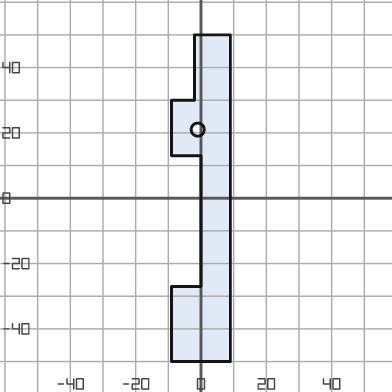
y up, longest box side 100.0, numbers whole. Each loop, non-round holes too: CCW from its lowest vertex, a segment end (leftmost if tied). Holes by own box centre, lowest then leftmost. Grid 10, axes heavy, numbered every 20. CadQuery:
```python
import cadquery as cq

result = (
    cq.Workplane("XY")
    .moveTo(-9.0, -50.0)
    .lineTo(9.0, -50.0)
    .lineTo(9.0, 50.0)
    .lineTo(-2.0, 50.0)
    .lineTo(-2.0, 30.0)
    .lineTo(-9.0, 30.0)
    .lineTo(-9.0, 13.0)
    .lineTo(0.0, 13.0)
    .lineTo(0.0, -27.0)
    .lineTo(-9.0, -27.0)
    .close()
    .moveTo(-1.0, 21.0)
    .circle(2.0)
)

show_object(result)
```